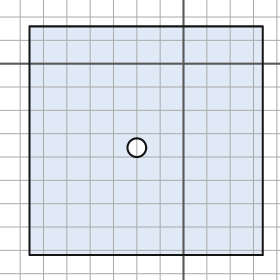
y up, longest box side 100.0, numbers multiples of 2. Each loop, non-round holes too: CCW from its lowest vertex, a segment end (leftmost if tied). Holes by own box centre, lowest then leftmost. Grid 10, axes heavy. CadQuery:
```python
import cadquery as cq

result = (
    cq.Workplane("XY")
    .moveTo(-66.0, -82.0)
    .lineTo(34.0, -82.0)
    .lineTo(34.0, 16.0)
    .lineTo(-66.0, 16.0)
    .close()
    .moveTo(-20.0, -36.0)
    .circle(4.0)
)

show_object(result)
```